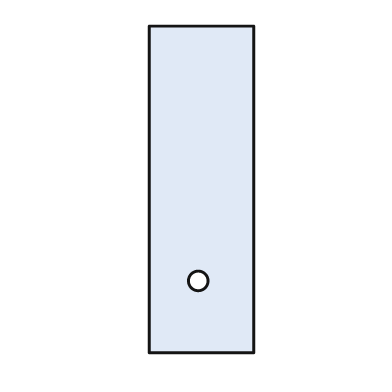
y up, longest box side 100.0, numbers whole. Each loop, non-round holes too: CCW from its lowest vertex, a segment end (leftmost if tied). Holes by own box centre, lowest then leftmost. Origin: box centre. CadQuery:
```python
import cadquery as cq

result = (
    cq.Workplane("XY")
    .moveTo(-16.0, -50.0)
    .lineTo(16.0, -50.0)
    .lineTo(16.0, 50.0)
    .lineTo(-16.0, 50.0)
    .close()
    .moveTo(-1.0, -28.0)
    .circle(3.0)
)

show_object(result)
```